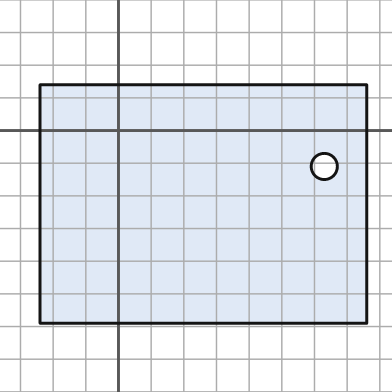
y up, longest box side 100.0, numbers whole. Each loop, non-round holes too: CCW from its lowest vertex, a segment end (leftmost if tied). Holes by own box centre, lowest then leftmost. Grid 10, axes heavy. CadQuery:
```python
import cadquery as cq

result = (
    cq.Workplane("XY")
    .moveTo(-24.0, -59.0)
    .lineTo(76.0, -59.0)
    .lineTo(76.0, 14.0)
    .lineTo(-24.0, 14.0)
    .close()
    .moveTo(63.0, -11.0)
    .circle(4.0)
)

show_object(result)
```